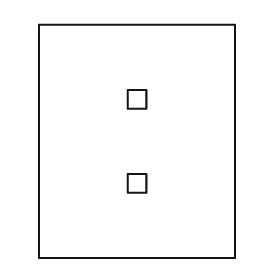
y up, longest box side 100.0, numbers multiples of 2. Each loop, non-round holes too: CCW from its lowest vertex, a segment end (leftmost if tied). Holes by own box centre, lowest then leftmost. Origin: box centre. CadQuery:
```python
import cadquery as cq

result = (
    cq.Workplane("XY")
    .moveTo(-42.0, -50.0)
    .lineTo(42.0, -50.0)
    .lineTo(42.0, 50.0)
    .lineTo(-42.0, 50.0)
    .close()
    .moveTo(-4.0, -22.0)
    .lineTo(4.0, -22.0)
    .lineTo(4.0, -14.0)
    .lineTo(-4.0, -14.0)
    .close()
    .moveTo(-4.0, 14.0)
    .lineTo(4.0, 14.0)
    .lineTo(4.0, 22.0)
    .lineTo(-4.0, 22.0)
    .close()
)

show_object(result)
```